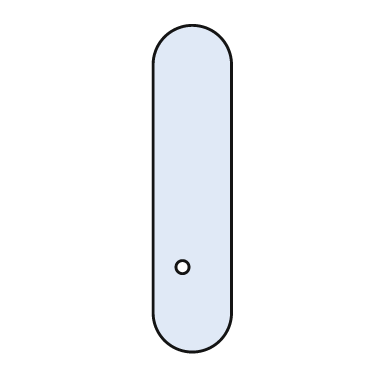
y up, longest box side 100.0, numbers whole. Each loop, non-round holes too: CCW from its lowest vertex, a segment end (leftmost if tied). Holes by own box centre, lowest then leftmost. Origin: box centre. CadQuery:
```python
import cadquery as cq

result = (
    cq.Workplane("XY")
    .moveTo(-12.0, -38.0)
    .threePointArc((0.0, -50.0), (12.0, -38.0))
    .lineTo(12.0, 38.0)
    .threePointArc((0.0, 50.0), (-12.0, 38.0))
    .close()
    .moveTo(-3.0, -24.0)
    .circle(2.0)
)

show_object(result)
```